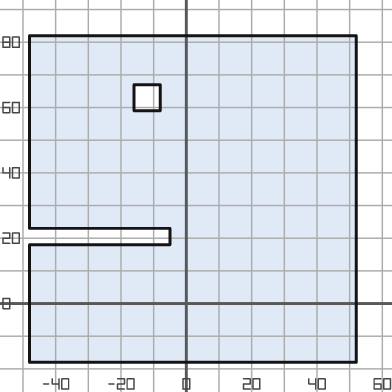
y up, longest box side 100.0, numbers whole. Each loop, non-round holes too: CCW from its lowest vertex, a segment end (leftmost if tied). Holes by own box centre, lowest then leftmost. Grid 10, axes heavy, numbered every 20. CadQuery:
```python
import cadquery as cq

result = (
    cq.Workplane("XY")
    .moveTo(-48.0, -18.0)
    .lineTo(52.0, -18.0)
    .lineTo(52.0, 82.0)
    .lineTo(-48.0, 82.0)
    .lineTo(-48.0, 23.0)
    .lineTo(-5.0, 23.0)
    .lineTo(-5.0, 18.0)
    .lineTo(-48.0, 18.0)
    .close()
    .moveTo(-16.0, 59.0)
    .lineTo(-8.0, 59.0)
    .lineTo(-8.0, 67.0)
    .lineTo(-16.0, 67.0)
    .close()
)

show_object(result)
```